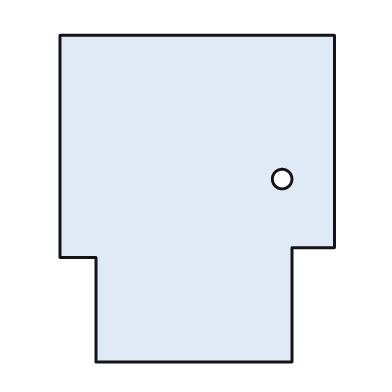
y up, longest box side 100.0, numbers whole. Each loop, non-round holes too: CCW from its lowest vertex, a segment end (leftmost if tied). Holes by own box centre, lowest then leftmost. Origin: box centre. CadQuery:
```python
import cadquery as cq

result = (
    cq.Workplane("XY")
    .moveTo(-31.0, -50.0)
    .lineTo(29.0, -50.0)
    .lineTo(29.0, -15.0)
    .lineTo(42.0, -15.0)
    .lineTo(42.0, 50.0)
    .lineTo(-42.0, 50.0)
    .lineTo(-42.0, -18.0)
    .lineTo(-31.0, -18.0)
    .close()
    .moveTo(26.0, 6.0)
    .circle(3.0)
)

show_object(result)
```